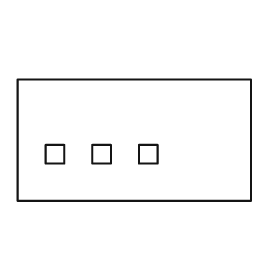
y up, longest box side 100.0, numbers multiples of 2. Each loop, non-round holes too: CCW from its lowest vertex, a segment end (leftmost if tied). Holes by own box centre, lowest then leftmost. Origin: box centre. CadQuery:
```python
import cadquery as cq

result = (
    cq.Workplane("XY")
    .moveTo(-50.0, -26.0)
    .lineTo(50.0, -26.0)
    .lineTo(50.0, 26.0)
    .lineTo(-50.0, 26.0)
    .close()
    .moveTo(-38.0, -10.0)
    .lineTo(-30.0, -10.0)
    .lineTo(-30.0, -2.0)
    .lineTo(-38.0, -2.0)
    .close()
    .moveTo(-18.0, -10.0)
    .lineTo(-10.0, -10.0)
    .lineTo(-10.0, -2.0)
    .lineTo(-18.0, -2.0)
    .close()
    .moveTo(2.0, -10.0)
    .lineTo(10.0, -10.0)
    .lineTo(10.0, -2.0)
    .lineTo(2.0, -2.0)
    .close()
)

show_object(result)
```